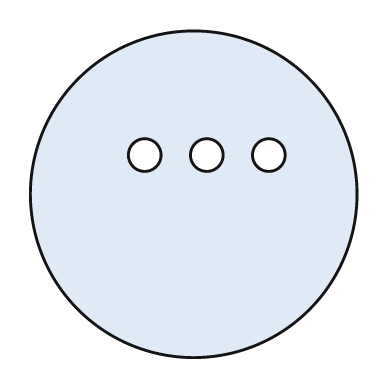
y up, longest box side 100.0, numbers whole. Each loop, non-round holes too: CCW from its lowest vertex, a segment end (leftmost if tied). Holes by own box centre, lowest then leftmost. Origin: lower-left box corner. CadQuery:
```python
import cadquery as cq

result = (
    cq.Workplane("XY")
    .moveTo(50.0, 50.0)
    .circle(50.0)
    .moveTo(35.0, 62.0)
    .circle(5.0)
    .moveTo(54.0, 62.0)
    .circle(5.0)
    .moveTo(73.0, 62.0)
    .circle(5.0)
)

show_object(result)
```